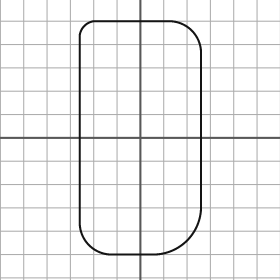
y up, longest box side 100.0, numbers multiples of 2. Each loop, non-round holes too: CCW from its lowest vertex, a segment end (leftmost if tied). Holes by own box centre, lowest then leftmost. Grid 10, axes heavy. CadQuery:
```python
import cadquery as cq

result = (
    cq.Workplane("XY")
    .moveTo(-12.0, -50.0)
    .lineTo(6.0, -50.0)
    .threePointArc((20.0, -44.0), (26.0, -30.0))
    .lineTo(26.0, 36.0)
    .threePointArc((22.0, 46.0), (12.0, 50.0))
    .lineTo(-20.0, 50.0)
    .threePointArc((-24.0, 48.0), (-26.0, 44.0))
    .lineTo(-26.0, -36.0)
    .threePointArc((-22.0, -46.0), (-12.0, -50.0))
    .close()
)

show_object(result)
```